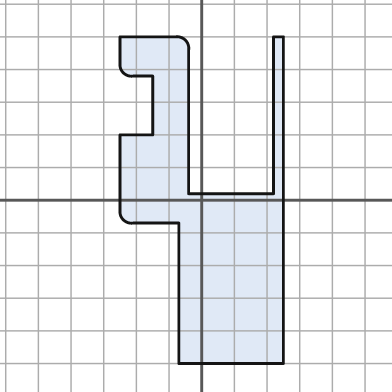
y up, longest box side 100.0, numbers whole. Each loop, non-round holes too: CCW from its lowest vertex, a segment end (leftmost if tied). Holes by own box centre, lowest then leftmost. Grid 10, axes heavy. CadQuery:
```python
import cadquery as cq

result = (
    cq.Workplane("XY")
    .moveTo(-7.0, -50.0)
    .lineTo(25.0, -50.0)
    .lineTo(25.0, 50.0)
    .lineTo(22.0, 50.0)
    .lineTo(22.0, 2.0)
    .lineTo(-4.0, 2.0)
    .lineTo(-4.0, 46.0)
    .threePointArc((-5.0, 49.0), (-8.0, 50.0))
    .lineTo(-25.0, 50.0)
    .lineTo(-25.0, 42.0)
    .threePointArc((-24.0, 39.0), (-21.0, 38.0))
    .lineTo(-15.0, 38.0)
    .lineTo(-15.0, 20.0)
    .lineTo(-25.0, 20.0)
    .lineTo(-25.0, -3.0)
    .threePointArc((-24.0, -6.0), (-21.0, -7.0))
    .lineTo(-7.0, -7.0)
    .close()
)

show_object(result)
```